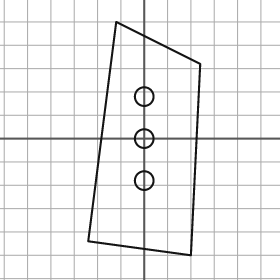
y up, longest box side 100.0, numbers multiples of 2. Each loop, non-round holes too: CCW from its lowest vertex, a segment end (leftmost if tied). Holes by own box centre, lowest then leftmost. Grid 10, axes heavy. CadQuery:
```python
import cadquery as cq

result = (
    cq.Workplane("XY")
    .moveTo(20.0, -50.0)
    .lineTo(24.0, 32.0)
    .lineTo(-12.0, 50.0)
    .lineTo(-24.0, -44.0)
    .close()
    .moveTo(0.0, -18.0)
    .circle(4.0)
    .moveTo(0.0, 0.0)
    .circle(4.0)
    .moveTo(0.0, 18.0)
    .circle(4.0)
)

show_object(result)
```